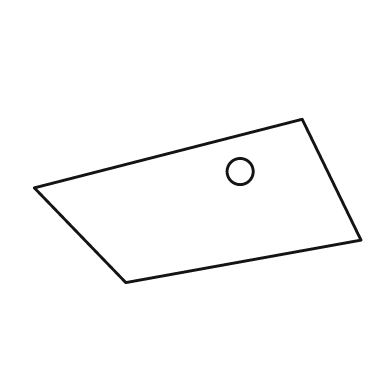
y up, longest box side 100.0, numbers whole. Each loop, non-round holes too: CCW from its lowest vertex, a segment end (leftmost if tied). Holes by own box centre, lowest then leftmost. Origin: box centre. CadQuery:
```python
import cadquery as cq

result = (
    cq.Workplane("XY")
    .moveTo(-22.0, -25.0)
    .lineTo(50.0, -12.0)
    .lineTo(32.0, 25.0)
    .lineTo(-50.0, 4.0)
    .close()
    .moveTo(13.0, 9.0)
    .circle(4.0)
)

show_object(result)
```